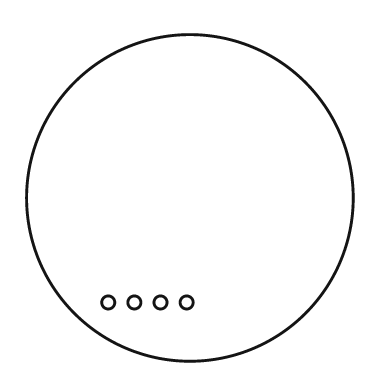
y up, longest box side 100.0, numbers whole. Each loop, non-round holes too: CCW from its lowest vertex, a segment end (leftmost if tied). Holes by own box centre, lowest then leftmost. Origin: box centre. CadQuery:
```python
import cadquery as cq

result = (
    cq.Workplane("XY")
    .moveTo(0.0, 0.0)
    .circle(50.0)
    .moveTo(-25.0, -32.0)
    .circle(2.0)
    .moveTo(-17.0, -32.0)
    .circle(2.0)
    .moveTo(-9.0, -32.0)
    .circle(2.0)
    .moveTo(-1.0, -32.0)
    .circle(2.0)
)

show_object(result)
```